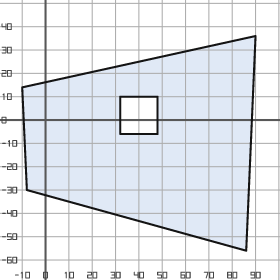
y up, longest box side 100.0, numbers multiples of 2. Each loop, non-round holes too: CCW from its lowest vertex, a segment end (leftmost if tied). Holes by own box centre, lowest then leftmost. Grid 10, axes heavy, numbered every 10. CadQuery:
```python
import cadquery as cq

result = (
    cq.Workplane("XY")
    .moveTo(86.0, -56.0)
    .lineTo(90.0, 36.0)
    .lineTo(-10.0, 14.0)
    .lineTo(-8.0, -30.0)
    .close()
    .moveTo(32.0, -6.0)
    .lineTo(48.0, -6.0)
    .lineTo(48.0, 10.0)
    .lineTo(32.0, 10.0)
    .close()
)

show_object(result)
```